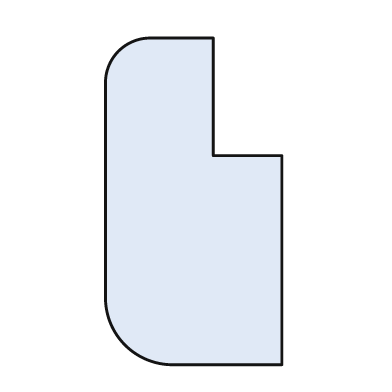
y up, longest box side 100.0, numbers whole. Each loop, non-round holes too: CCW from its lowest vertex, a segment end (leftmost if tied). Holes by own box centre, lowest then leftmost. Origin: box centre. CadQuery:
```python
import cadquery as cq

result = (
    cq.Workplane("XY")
    .moveTo(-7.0, -50.0)
    .lineTo(27.0, -50.0)
    .lineTo(27.0, 14.0)
    .lineTo(6.0, 14.0)
    .lineTo(6.0, 50.0)
    .lineTo(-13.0, 50.0)
    .threePointArc((-23.0, 46.0), (-27.0, 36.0))
    .lineTo(-27.0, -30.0)
    .threePointArc((-21.0, -44.0), (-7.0, -50.0))
    .close()
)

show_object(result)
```